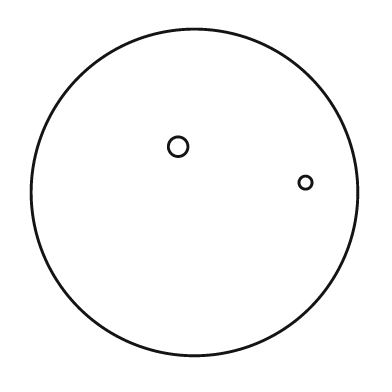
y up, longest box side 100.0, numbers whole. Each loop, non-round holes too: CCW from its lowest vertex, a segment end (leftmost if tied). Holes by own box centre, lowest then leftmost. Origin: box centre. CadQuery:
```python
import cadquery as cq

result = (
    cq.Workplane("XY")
    .moveTo(0.0, 0.0)
    .circle(50.0)
    .moveTo(34.0, 3.0)
    .circle(2.0)
    .moveTo(-5.0, 14.0)
    .circle(3.0)
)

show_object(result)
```